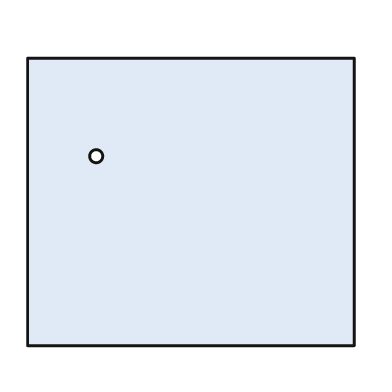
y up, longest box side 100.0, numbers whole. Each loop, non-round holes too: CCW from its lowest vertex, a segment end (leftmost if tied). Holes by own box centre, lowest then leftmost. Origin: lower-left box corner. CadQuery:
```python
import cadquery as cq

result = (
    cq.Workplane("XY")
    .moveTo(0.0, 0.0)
    .lineTo(100.0, 0.0)
    .lineTo(100.0, 88.0)
    .lineTo(0.0, 88.0)
    .close()
    .moveTo(21.0, 58.0)
    .circle(2.0)
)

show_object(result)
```